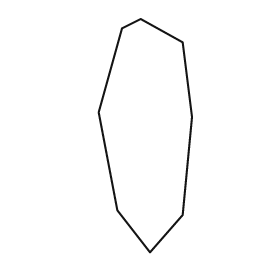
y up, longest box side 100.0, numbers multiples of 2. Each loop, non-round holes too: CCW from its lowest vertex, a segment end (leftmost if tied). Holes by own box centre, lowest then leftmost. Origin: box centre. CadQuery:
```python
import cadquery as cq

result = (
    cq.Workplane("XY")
    .moveTo(2.0, -50.0)
    .lineTo(16.0, -34.0)
    .lineTo(20.0, 8.0)
    .lineTo(16.0, 40.0)
    .lineTo(-2.0, 50.0)
    .lineTo(-10.0, 46.0)
    .lineTo(-20.0, 10.0)
    .lineTo(-12.0, -32.0)
    .close()
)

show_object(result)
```